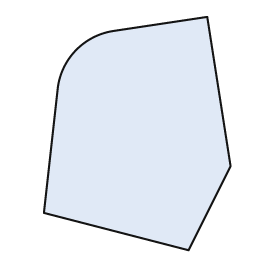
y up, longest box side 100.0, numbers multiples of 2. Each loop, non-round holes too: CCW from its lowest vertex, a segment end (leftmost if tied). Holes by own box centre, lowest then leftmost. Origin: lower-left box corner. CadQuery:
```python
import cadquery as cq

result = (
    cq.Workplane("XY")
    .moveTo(62.0, 0.0)
    .lineTo(80.0, 36.0)
    .lineTo(70.0, 100.0)
    .lineTo(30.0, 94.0)
    .threePointArc((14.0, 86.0), (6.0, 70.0))
    .lineTo(0.0, 16.0)
    .close()
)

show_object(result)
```